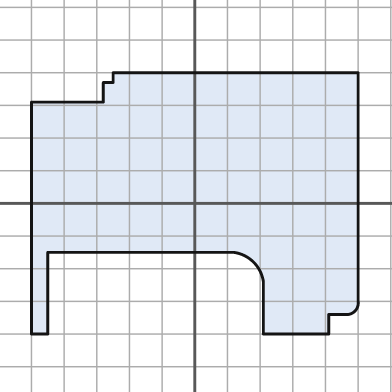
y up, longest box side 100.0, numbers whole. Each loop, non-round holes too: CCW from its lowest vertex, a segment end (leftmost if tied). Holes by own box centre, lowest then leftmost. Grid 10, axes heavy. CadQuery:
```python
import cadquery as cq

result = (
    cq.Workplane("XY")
    .moveTo(-50.0, -40.0)
    .lineTo(-45.0, -40.0)
    .lineTo(-45.0, -15.0)
    .lineTo(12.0, -15.0)
    .threePointArc((18.0, -18.0), (21.0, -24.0))
    .lineTo(21.0, -40.0)
    .lineTo(41.0, -40.0)
    .lineTo(41.0, -34.0)
    .lineTo(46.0, -34.0)
    .threePointArc((49.0, -33.0), (50.0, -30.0))
    .lineTo(50.0, 40.0)
    .lineTo(-25.0, 40.0)
    .lineTo(-25.0, 37.0)
    .lineTo(-28.0, 37.0)
    .lineTo(-28.0, 31.0)
    .lineTo(-50.0, 31.0)
    .close()
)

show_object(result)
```